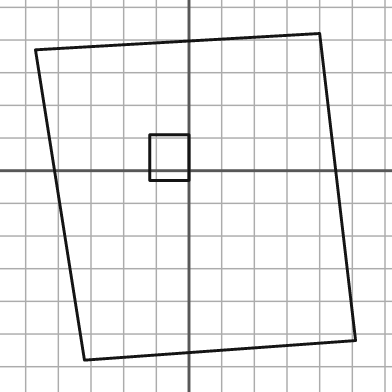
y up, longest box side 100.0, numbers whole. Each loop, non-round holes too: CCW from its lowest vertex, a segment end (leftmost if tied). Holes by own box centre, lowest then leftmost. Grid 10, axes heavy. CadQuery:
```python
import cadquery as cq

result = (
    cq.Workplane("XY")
    .moveTo(-32.0, -58.0)
    .lineTo(51.0, -52.0)
    .lineTo(40.0, 42.0)
    .lineTo(-47.0, 37.0)
    .close()
    .moveTo(-12.0, -3.0)
    .lineTo(0.0, -3.0)
    .lineTo(0.0, 11.0)
    .lineTo(-12.0, 11.0)
    .close()
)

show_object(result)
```